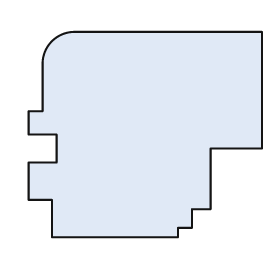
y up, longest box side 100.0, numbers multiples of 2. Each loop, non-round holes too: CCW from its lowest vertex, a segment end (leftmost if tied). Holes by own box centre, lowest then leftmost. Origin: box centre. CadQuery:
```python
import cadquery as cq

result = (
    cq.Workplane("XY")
    .moveTo(-40.0, -44.0)
    .lineTo(14.0, -44.0)
    .lineTo(14.0, -40.0)
    .lineTo(20.0, -40.0)
    .lineTo(20.0, -32.0)
    .lineTo(28.0, -32.0)
    .lineTo(28.0, -6.0)
    .lineTo(50.0, -6.0)
    .lineTo(50.0, 44.0)
    .lineTo(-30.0, 44.0)
    .threePointArc((-40.0, 40.0), (-44.0, 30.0))
    .lineTo(-44.0, 10.0)
    .lineTo(-50.0, 10.0)
    .lineTo(-50.0, 0.0)
    .lineTo(-38.0, 0.0)
    .lineTo(-38.0, -12.0)
    .lineTo(-50.0, -12.0)
    .lineTo(-50.0, -28.0)
    .lineTo(-40.0, -28.0)
    .close()
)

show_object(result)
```